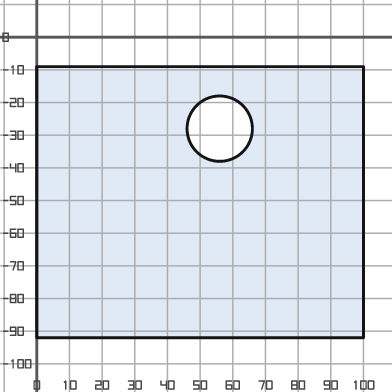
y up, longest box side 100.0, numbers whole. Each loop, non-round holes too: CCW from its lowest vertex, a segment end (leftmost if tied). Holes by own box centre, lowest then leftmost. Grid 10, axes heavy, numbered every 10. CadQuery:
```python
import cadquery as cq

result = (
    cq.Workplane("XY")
    .moveTo(0.0, -92.0)
    .lineTo(100.0, -92.0)
    .lineTo(100.0, -9.0)
    .lineTo(0.0, -9.0)
    .close()
    .moveTo(56.0, -28.0)
    .circle(10.0)
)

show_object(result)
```